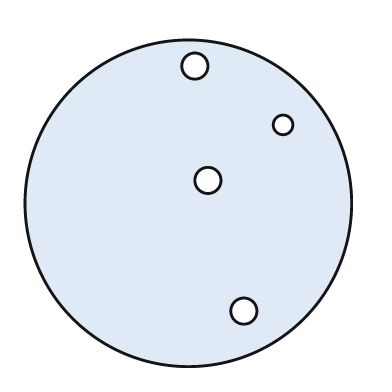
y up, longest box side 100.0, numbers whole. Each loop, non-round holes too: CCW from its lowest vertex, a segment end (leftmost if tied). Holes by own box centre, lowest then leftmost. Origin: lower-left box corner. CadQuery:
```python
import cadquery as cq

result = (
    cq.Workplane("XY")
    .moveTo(50.0, 50.0)
    .circle(50.0)
    .moveTo(67.0, 17.0)
    .circle(4.0)
    .moveTo(56.0, 57.0)
    .circle(4.0)
    .moveTo(79.0, 74.0)
    .circle(3.0)
    .moveTo(52.0, 92.0)
    .circle(4.0)
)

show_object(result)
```